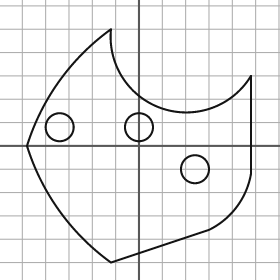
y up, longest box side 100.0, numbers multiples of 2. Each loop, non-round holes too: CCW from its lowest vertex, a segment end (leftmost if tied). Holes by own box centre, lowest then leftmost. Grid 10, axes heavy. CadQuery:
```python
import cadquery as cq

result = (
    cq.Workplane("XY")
    .moveTo(-12.0, -50.0)
    .lineTo(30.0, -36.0)
    .threePointArc((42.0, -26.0), (48.0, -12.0))
    .lineTo(48.0, 30.0)
    .threePointArc((10.0, 16.0), (-12.0, 50.0))
    .threePointArc((-34.0, 28.0), (-48.0, 0.0))
    .threePointArc((-34.0, -28.0), (-12.0, -50.0))
    .close()
    .moveTo(24.0, -10.0)
    .circle(6.0)
    .moveTo(-34.0, 8.0)
    .circle(6.0)
    .moveTo(0.0, 8.0)
    .circle(6.0)
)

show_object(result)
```